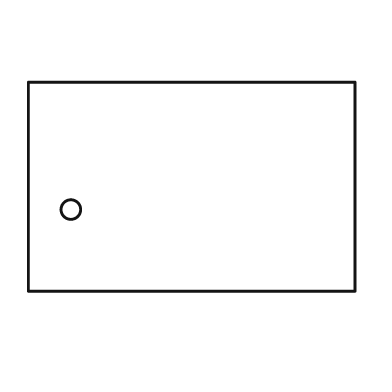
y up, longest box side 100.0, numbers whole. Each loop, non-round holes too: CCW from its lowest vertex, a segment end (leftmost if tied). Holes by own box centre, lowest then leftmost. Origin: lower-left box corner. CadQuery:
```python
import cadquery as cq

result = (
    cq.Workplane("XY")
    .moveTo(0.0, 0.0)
    .lineTo(100.0, 0.0)
    .lineTo(100.0, 64.0)
    .lineTo(0.0, 64.0)
    .close()
    .moveTo(13.0, 25.0)
    .circle(3.0)
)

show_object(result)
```